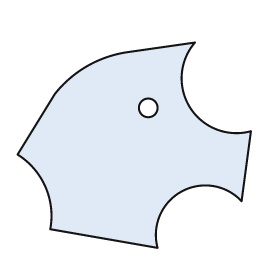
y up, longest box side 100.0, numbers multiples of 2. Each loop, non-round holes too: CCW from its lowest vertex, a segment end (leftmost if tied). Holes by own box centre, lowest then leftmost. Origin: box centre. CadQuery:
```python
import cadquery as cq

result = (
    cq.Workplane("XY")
    .moveTo(10.0, -44.0)
    .threePointArc((20.0, -20.0), (46.0, -24.0))
    .lineTo(50.0, 6.0)
    .threePointArc((24.0, 16.0), (26.0, 44.0))
    .lineTo(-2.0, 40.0)
    .threePointArc((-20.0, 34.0), (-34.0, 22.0))
    .lineTo(-50.0, -4.0)
    .threePointArc((-38.0, -18.0), (-36.0, -36.0))
    .close()
    .moveTo(6.0, 16.0)
    .circle(4.0)
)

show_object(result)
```